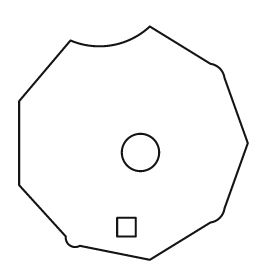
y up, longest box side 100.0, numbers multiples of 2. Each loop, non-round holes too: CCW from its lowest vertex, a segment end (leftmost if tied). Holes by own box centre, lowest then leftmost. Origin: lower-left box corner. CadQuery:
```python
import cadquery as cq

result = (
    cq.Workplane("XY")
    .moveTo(56.0, 0.0)
    .lineTo(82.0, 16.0)
    .threePointArc((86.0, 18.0), (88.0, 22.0))
    .lineTo(98.0, 50.0)
    .lineTo(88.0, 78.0)
    .threePointArc((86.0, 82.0), (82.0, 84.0))
    .lineTo(56.0, 100.0)
    .threePointArc((40.0, 92.0), (22.0, 94.0))
    .lineTo(0.0, 68.0)
    .lineTo(0.0, 32.0)
    .lineTo(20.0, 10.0)
    .threePointArc((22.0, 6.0), (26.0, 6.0))
    .close()
    .moveTo(42.0, 10.0)
    .lineTo(50.0, 10.0)
    .lineTo(50.0, 18.0)
    .lineTo(42.0, 18.0)
    .close()
    .moveTo(52.0, 46.0)
    .circle(8.0)
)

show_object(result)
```